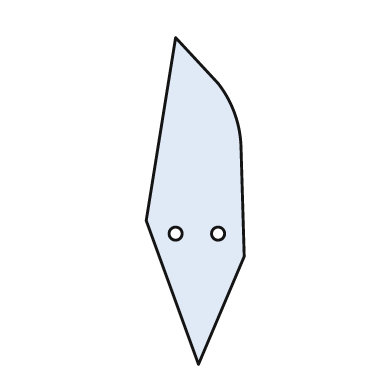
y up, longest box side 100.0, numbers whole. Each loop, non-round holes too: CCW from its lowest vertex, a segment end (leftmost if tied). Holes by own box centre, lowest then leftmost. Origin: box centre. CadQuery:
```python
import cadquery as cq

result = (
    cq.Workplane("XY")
    .moveTo(1.0, -50.0)
    .lineTo(15.0, -17.0)
    .lineTo(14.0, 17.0)
    .threePointArc((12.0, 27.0), (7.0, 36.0))
    .lineTo(-6.0, 50.0)
    .lineTo(-15.0, -6.0)
    .close()
    .moveTo(-6.0, -10.0)
    .circle(2.0)
    .moveTo(7.0, -10.0)
    .circle(2.0)
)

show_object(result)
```